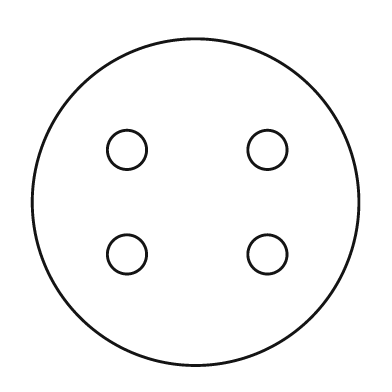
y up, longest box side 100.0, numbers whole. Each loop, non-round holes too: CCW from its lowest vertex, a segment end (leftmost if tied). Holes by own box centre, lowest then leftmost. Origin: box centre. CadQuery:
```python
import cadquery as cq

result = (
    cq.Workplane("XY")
    .moveTo(0.0, 0.0)
    .circle(50.0)
    .moveTo(-21.0, -16.0)
    .circle(6.0)
    .moveTo(22.0, -16.0)
    .circle(6.0)
    .moveTo(-21.0, 16.0)
    .circle(6.0)
    .moveTo(22.0, 16.0)
    .circle(6.0)
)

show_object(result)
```